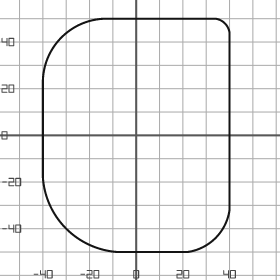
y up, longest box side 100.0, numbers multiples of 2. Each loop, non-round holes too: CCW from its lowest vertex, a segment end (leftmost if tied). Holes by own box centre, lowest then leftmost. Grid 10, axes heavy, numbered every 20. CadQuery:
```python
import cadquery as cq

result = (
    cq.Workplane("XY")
    .moveTo(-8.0, -50.0)
    .lineTo(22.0, -50.0)
    .threePointArc((34.0, -44.0), (40.0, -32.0))
    .lineTo(40.0, 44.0)
    .threePointArc((38.0, 48.0), (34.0, 50.0))
    .lineTo(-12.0, 50.0)
    .threePointArc((-32.0, 42.0), (-40.0, 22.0))
    .lineTo(-40.0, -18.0)
    .threePointArc((-30.0, -40.0), (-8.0, -50.0))
    .close()
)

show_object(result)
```